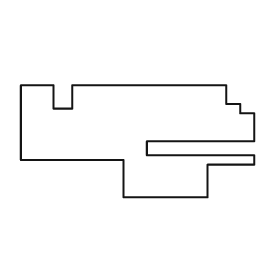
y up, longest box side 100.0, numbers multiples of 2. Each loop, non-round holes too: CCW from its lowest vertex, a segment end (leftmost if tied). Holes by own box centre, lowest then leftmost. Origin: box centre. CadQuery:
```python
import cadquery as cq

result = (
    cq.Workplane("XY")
    .moveTo(-6.0, -24.0)
    .lineTo(30.0, -24.0)
    .lineTo(30.0, -10.0)
    .lineTo(50.0, -10.0)
    .lineTo(50.0, -6.0)
    .lineTo(4.0, -6.0)
    .lineTo(4.0, 0.0)
    .lineTo(50.0, 0.0)
    .lineTo(50.0, 12.0)
    .lineTo(44.0, 12.0)
    .lineTo(44.0, 16.0)
    .lineTo(38.0, 16.0)
    .lineTo(38.0, 24.0)
    .lineTo(-28.0, 24.0)
    .lineTo(-28.0, 14.0)
    .lineTo(-36.0, 14.0)
    .lineTo(-36.0, 24.0)
    .lineTo(-50.0, 24.0)
    .lineTo(-50.0, -8.0)
    .lineTo(-6.0, -8.0)
    .close()
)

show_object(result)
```